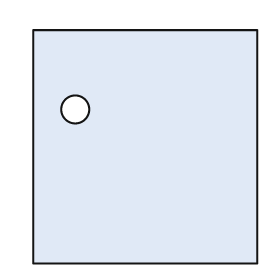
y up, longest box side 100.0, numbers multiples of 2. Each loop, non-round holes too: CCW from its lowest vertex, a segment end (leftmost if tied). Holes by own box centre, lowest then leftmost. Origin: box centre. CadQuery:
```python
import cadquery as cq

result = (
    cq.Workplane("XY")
    .moveTo(-48.0, -50.0)
    .lineTo(48.0, -50.0)
    .lineTo(48.0, 50.0)
    .lineTo(-48.0, 50.0)
    .close()
    .moveTo(-30.0, 16.0)
    .circle(6.0)
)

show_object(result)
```